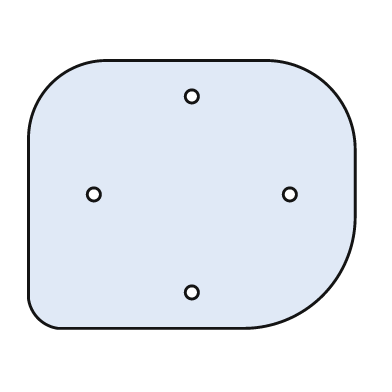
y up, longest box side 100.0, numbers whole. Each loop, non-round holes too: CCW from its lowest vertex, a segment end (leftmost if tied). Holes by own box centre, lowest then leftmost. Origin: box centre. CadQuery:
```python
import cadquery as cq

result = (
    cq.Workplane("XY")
    .moveTo(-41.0, -41.0)
    .lineTo(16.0, -41.0)
    .threePointArc((40.0, -31.0), (50.0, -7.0))
    .lineTo(50.0, 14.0)
    .threePointArc((42.0, 33.0), (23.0, 41.0))
    .lineTo(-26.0, 41.0)
    .threePointArc((-43.0, 34.0), (-50.0, 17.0))
    .lineTo(-50.0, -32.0)
    .threePointArc((-47.0, -38.0), (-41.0, -41.0))
    .close()
    .moveTo(0.0, -30.0)
    .circle(2.0)
    .moveTo(-30.0, 0.0)
    .circle(2.0)
    .moveTo(30.0, 0.0)
    .circle(2.0)
    .moveTo(0.0, 30.0)
    .circle(2.0)
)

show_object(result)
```